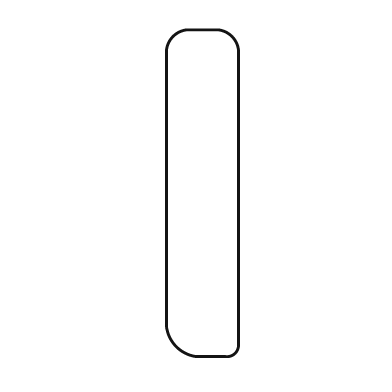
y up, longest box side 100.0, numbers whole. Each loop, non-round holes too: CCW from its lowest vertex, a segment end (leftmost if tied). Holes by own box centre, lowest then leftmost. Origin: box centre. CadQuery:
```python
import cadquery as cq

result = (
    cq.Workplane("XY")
    .moveTo(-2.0, -50.0)
    .lineTo(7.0, -50.0)
    .threePointArc((10.0, -49.0), (11.0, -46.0))
    .lineTo(11.0, 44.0)
    .threePointArc((9.0, 48.0), (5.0, 50.0))
    .lineTo(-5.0, 50.0)
    .threePointArc((-9.0, 48.0), (-11.0, 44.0))
    .lineTo(-11.0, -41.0)
    .threePointArc((-8.0, -47.0), (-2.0, -50.0))
    .close()
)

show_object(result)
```